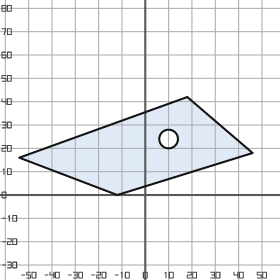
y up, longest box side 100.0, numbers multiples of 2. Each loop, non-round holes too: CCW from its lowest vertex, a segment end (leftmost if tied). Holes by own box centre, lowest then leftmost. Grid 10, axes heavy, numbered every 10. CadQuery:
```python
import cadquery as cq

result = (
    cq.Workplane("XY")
    .moveTo(-12.0, 0.0)
    .lineTo(46.0, 18.0)
    .lineTo(18.0, 42.0)
    .lineTo(-54.0, 16.0)
    .close()
    .moveTo(10.0, 24.0)
    .circle(4.0)
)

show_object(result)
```